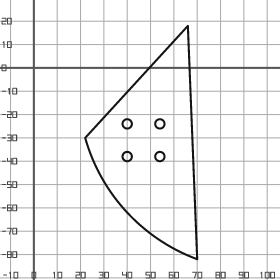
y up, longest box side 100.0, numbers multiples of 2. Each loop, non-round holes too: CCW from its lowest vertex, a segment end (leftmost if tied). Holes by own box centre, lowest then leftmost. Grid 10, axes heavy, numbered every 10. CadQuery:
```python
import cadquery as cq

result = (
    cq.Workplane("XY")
    .moveTo(70.0, -82.0)
    .lineTo(66.0, 18.0)
    .lineTo(22.0, -30.0)
    .threePointArc((40.0, -62.0), (70.0, -82.0))
    .close()
    .moveTo(40.0, -38.0)
    .circle(2.0)
    .moveTo(54.0, -38.0)
    .circle(2.0)
    .moveTo(40.0, -24.0)
    .circle(2.0)
    .moveTo(54.0, -24.0)
    .circle(2.0)
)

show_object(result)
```